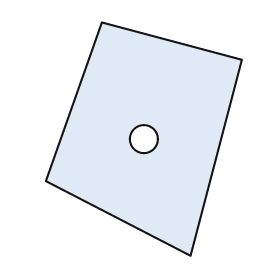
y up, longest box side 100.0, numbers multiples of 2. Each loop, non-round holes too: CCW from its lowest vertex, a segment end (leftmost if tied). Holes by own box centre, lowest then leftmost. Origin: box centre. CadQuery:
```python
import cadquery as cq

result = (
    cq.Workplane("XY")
    .moveTo(20.0, -50.0)
    .lineTo(42.0, 34.0)
    .lineTo(-18.0, 50.0)
    .lineTo(-42.0, -18.0)
    .close()
    .moveTo(0.0, 0.0)
    .circle(6.0)
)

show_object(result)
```